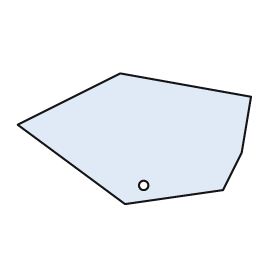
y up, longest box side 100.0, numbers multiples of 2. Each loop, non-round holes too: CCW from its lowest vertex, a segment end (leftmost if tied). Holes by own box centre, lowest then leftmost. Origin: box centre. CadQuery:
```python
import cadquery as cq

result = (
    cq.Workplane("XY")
    .moveTo(-4.0, -28.0)
    .lineTo(38.0, -22.0)
    .lineTo(46.0, -6.0)
    .lineTo(50.0, 18.0)
    .lineTo(-6.0, 28.0)
    .lineTo(-50.0, 6.0)
    .close()
    .moveTo(4.0, -20.0)
    .circle(2.0)
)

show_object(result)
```